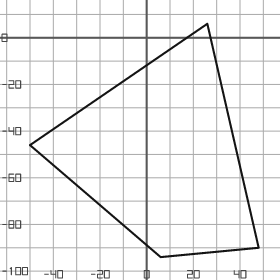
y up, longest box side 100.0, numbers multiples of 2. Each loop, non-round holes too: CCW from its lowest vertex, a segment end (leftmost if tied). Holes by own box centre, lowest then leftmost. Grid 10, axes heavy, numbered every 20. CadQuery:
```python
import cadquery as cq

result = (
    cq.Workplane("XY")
    .moveTo(6.0, -94.0)
    .lineTo(48.0, -90.0)
    .lineTo(26.0, 6.0)
    .lineTo(-50.0, -46.0)
    .close()
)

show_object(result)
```